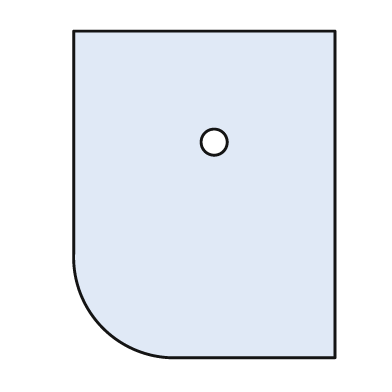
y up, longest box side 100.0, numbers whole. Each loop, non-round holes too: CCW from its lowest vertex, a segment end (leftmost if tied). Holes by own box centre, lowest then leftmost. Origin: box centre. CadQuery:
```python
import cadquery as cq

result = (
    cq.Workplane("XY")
    .moveTo(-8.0, -50.0)
    .lineTo(40.0, -50.0)
    .lineTo(40.0, 50.0)
    .lineTo(-40.0, 50.0)
    .lineTo(-40.0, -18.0)
    .threePointArc((-31.0, -41.0), (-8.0, -50.0))
    .close()
    .moveTo(3.0, 16.0)
    .circle(4.0)
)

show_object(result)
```